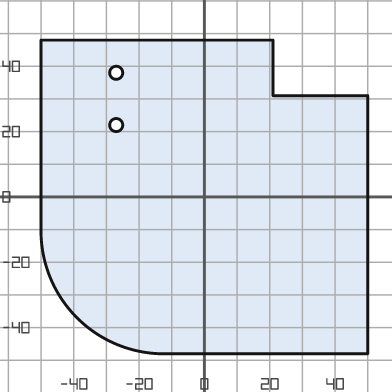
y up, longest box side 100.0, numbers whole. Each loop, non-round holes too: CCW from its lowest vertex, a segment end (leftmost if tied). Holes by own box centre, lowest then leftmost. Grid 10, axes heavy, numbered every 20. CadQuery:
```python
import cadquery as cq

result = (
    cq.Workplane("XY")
    .moveTo(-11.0, -48.0)
    .lineTo(50.0, -48.0)
    .lineTo(50.0, 31.0)
    .lineTo(21.0, 31.0)
    .lineTo(21.0, 48.0)
    .lineTo(-50.0, 48.0)
    .lineTo(-50.0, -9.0)
    .threePointArc((-39.0, -37.0), (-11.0, -48.0))
    .close()
    .moveTo(-27.0, 22.0)
    .circle(2.0)
    .moveTo(-27.0, 38.0)
    .circle(2.0)
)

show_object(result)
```